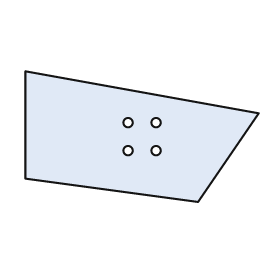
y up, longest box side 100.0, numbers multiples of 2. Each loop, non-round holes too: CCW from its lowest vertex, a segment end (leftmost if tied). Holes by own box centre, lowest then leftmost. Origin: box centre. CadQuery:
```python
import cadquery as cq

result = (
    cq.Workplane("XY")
    .moveTo(24.0, -28.0)
    .lineTo(50.0, 10.0)
    .lineTo(-50.0, 28.0)
    .lineTo(-50.0, -18.0)
    .close()
    .moveTo(-6.0, -6.0)
    .circle(2.0)
    .moveTo(6.0, -6.0)
    .circle(2.0)
    .moveTo(-6.0, 6.0)
    .circle(2.0)
    .moveTo(6.0, 6.0)
    .circle(2.0)
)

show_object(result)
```